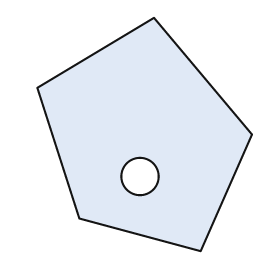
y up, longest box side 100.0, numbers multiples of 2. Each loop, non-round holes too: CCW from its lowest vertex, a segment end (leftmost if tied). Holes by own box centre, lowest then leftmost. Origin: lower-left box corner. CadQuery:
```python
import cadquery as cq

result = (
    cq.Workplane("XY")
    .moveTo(70.0, 0.0)
    .lineTo(92.0, 50.0)
    .lineTo(50.0, 100.0)
    .lineTo(0.0, 70.0)
    .lineTo(18.0, 14.0)
    .close()
    .moveTo(44.0, 32.0)
    .circle(8.0)
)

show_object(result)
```